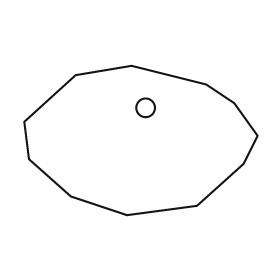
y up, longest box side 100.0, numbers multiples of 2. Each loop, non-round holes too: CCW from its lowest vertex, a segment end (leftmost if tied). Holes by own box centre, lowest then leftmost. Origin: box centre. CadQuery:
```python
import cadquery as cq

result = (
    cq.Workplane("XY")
    .moveTo(-6.0, -32.0)
    .lineTo(24.0, -28.0)
    .lineTo(44.0, -10.0)
    .lineTo(50.0, 2.0)
    .lineTo(40.0, 16.0)
    .lineTo(28.0, 24.0)
    .lineTo(-4.0, 32.0)
    .lineTo(-28.0, 28.0)
    .lineTo(-50.0, 8.0)
    .lineTo(-48.0, -8.0)
    .lineTo(-30.0, -24.0)
    .close()
    .moveTo(2.0, 14.0)
    .circle(4.0)
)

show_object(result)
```